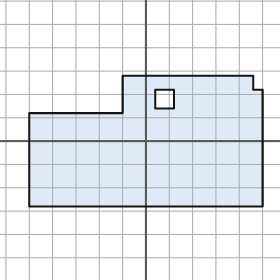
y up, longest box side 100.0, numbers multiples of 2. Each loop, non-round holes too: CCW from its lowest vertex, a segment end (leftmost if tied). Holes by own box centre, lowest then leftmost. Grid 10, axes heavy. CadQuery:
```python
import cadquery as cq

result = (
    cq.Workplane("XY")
    .moveTo(-50.0, -28.0)
    .lineTo(50.0, -28.0)
    .lineTo(50.0, 22.0)
    .lineTo(46.0, 22.0)
    .lineTo(46.0, 28.0)
    .lineTo(-10.0, 28.0)
    .lineTo(-10.0, 12.0)
    .lineTo(-50.0, 12.0)
    .close()
    .moveTo(4.0, 14.0)
    .lineTo(12.0, 14.0)
    .lineTo(12.0, 22.0)
    .lineTo(4.0, 22.0)
    .close()
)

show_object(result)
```